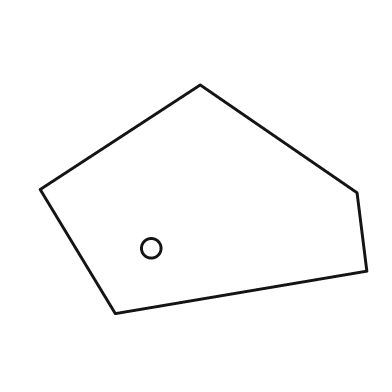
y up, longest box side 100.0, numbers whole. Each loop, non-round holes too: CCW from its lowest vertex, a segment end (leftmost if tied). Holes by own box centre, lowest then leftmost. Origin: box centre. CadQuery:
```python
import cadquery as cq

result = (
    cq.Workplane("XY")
    .moveTo(-27.0, -35.0)
    .lineTo(50.0, -22.0)
    .lineTo(47.0, 2.0)
    .lineTo(-1.0, 35.0)
    .lineTo(-50.0, 3.0)
    .close()
    .moveTo(-16.0, -15.0)
    .circle(3.0)
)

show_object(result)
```